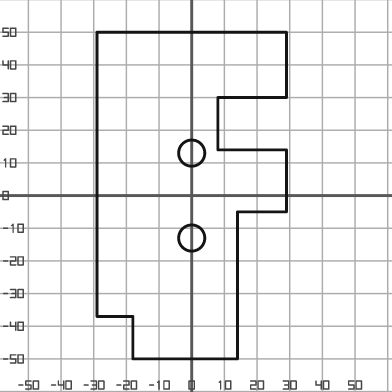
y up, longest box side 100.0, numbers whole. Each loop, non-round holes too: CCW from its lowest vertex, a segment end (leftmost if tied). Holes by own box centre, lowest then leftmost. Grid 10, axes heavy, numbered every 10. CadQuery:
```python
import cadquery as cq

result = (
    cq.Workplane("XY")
    .moveTo(-18.0, -50.0)
    .lineTo(14.0, -50.0)
    .lineTo(14.0, -5.0)
    .lineTo(29.0, -5.0)
    .lineTo(29.0, 14.0)
    .lineTo(8.0, 14.0)
    .lineTo(8.0, 30.0)
    .lineTo(29.0, 30.0)
    .lineTo(29.0, 50.0)
    .lineTo(-29.0, 50.0)
    .lineTo(-29.0, -37.0)
    .lineTo(-18.0, -37.0)
    .close()
    .moveTo(0.0, -13.0)
    .circle(4.0)
    .moveTo(0.0, 13.0)
    .circle(4.0)
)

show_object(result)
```